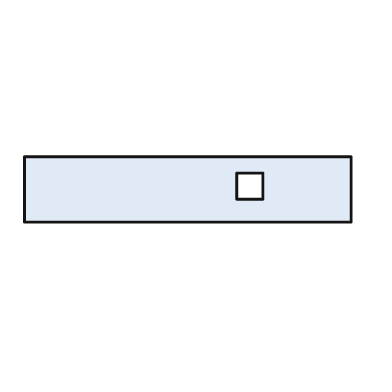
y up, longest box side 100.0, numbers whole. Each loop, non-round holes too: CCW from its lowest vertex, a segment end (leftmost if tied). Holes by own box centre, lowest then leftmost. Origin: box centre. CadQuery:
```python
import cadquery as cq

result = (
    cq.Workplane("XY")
    .moveTo(-50.0, -10.0)
    .lineTo(50.0, -10.0)
    .lineTo(50.0, 10.0)
    .lineTo(-50.0, 10.0)
    .close()
    .moveTo(15.0, -3.0)
    .lineTo(23.0, -3.0)
    .lineTo(23.0, 5.0)
    .lineTo(15.0, 5.0)
    .close()
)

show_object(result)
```